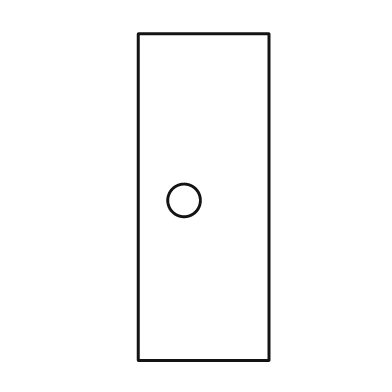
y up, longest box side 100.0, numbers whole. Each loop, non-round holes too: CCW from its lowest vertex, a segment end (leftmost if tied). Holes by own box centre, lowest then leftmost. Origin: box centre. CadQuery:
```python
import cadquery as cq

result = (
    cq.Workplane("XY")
    .moveTo(-20.0, -50.0)
    .lineTo(20.0, -50.0)
    .lineTo(20.0, 50.0)
    .lineTo(-20.0, 50.0)
    .close()
    .moveTo(-6.0, -1.0)
    .circle(5.0)
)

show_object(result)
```